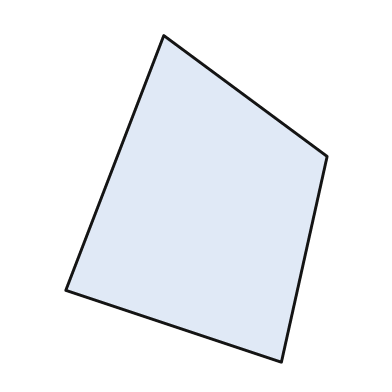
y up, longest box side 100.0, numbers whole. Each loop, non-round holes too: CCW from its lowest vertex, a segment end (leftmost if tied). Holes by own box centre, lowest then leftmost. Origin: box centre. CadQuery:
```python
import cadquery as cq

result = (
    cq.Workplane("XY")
    .moveTo(26.0, -50.0)
    .lineTo(40.0, 13.0)
    .lineTo(-10.0, 50.0)
    .lineTo(-40.0, -28.0)
    .close()
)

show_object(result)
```